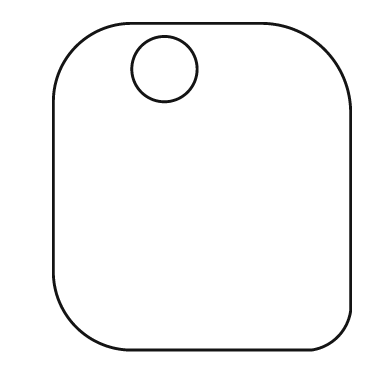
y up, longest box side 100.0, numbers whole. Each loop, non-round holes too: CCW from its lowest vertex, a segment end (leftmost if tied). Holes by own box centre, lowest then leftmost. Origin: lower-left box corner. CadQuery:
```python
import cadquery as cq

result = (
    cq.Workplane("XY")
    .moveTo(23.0, 0.0)
    .lineTo(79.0, 0.0)
    .threePointArc((87.0, 4.0), (91.0, 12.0))
    .lineTo(91.0, 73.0)
    .threePointArc((83.0, 92.0), (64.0, 100.0))
    .lineTo(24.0, 100.0)
    .threePointArc((7.0, 93.0), (0.0, 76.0))
    .lineTo(0.0, 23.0)
    .threePointArc((7.0, 7.0), (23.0, 0.0))
    .close()
    .moveTo(34.0, 86.0)
    .circle(10.0)
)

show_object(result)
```